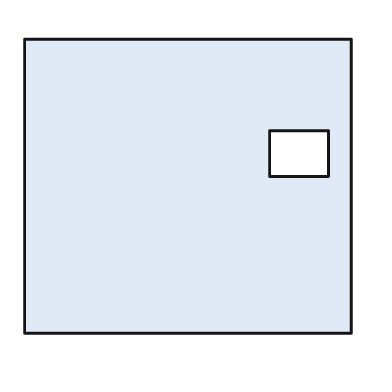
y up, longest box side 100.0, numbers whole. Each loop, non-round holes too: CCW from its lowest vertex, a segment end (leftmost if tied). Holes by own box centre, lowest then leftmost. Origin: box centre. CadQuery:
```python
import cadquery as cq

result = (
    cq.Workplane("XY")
    .moveTo(-50.0, -45.0)
    .lineTo(50.0, -45.0)
    .lineTo(50.0, 45.0)
    .lineTo(-50.0, 45.0)
    .close()
    .moveTo(25.0, 3.0)
    .lineTo(43.0, 3.0)
    .lineTo(43.0, 17.0)
    .lineTo(25.0, 17.0)
    .close()
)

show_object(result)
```